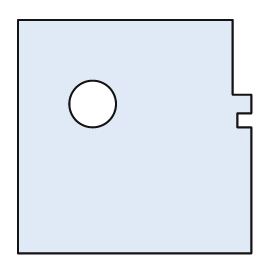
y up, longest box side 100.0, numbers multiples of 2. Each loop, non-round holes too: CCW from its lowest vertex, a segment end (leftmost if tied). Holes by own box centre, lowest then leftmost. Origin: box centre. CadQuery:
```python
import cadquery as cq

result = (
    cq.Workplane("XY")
    .moveTo(-50.0, -50.0)
    .lineTo(50.0, -50.0)
    .lineTo(50.0, 4.0)
    .lineTo(44.0, 4.0)
    .lineTo(44.0, 10.0)
    .lineTo(50.0, 10.0)
    .lineTo(50.0, 18.0)
    .lineTo(42.0, 18.0)
    .lineTo(42.0, 50.0)
    .lineTo(-50.0, 50.0)
    .close()
    .moveTo(-18.0, 14.0)
    .circle(10.0)
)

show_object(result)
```